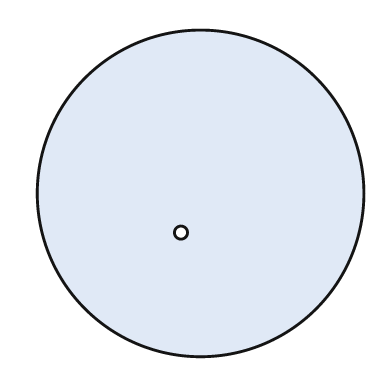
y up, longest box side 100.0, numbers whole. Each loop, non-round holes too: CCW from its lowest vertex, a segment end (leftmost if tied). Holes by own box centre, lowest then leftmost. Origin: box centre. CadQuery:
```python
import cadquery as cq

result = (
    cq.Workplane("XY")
    .moveTo(0.0, 0.0)
    .circle(50.0)
    .moveTo(-6.0, -12.0)
    .circle(2.0)
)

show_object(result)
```